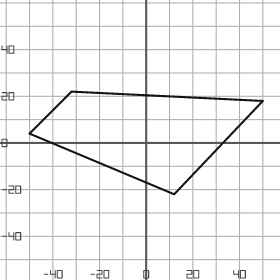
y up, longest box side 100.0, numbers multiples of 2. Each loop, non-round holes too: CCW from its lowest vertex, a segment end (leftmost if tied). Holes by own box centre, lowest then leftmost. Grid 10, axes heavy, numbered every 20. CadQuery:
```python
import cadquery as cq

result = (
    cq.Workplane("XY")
    .moveTo(12.0, -22.0)
    .lineTo(50.0, 18.0)
    .lineTo(-32.0, 22.0)
    .lineTo(-50.0, 4.0)
    .close()
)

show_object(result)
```